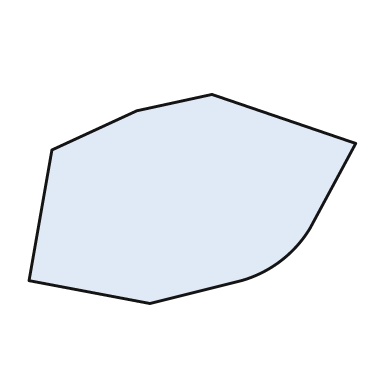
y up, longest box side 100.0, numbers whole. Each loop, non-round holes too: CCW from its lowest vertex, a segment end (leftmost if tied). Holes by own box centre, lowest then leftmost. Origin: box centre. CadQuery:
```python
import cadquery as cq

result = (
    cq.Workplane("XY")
    .moveTo(-13.0, -32.0)
    .lineTo(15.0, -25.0)
    .threePointArc((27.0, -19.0), (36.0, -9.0))
    .lineTo(50.0, 17.0)
    .lineTo(6.0, 32.0)
    .lineTo(-17.0, 27.0)
    .lineTo(-43.0, 15.0)
    .lineTo(-50.0, -25.0)
    .close()
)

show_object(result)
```